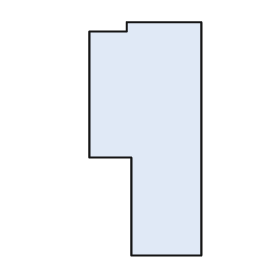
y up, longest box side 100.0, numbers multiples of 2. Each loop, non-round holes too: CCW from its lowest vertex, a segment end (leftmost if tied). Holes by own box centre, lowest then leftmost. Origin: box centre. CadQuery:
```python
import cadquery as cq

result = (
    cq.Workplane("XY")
    .moveTo(-6.0, -50.0)
    .lineTo(24.0, -50.0)
    .lineTo(24.0, 50.0)
    .lineTo(-8.0, 50.0)
    .lineTo(-8.0, 46.0)
    .lineTo(-24.0, 46.0)
    .lineTo(-24.0, -8.0)
    .lineTo(-6.0, -8.0)
    .close()
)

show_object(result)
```